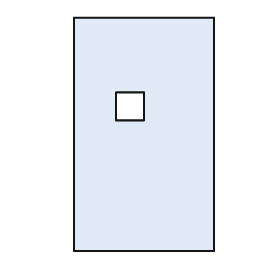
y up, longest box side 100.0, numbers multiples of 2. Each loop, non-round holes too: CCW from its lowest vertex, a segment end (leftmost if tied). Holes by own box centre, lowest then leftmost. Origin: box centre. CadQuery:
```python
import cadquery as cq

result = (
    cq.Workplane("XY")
    .moveTo(-30.0, -50.0)
    .lineTo(30.0, -50.0)
    .lineTo(30.0, 50.0)
    .lineTo(-30.0, 50.0)
    .close()
    .moveTo(-12.0, 6.0)
    .lineTo(0.0, 6.0)
    .lineTo(0.0, 18.0)
    .lineTo(-12.0, 18.0)
    .close()
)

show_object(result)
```